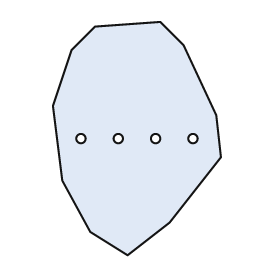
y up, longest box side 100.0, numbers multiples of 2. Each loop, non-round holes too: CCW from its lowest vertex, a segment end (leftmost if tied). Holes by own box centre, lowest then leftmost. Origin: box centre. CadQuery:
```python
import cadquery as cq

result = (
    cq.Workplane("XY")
    .moveTo(-4.0, -50.0)
    .lineTo(14.0, -36.0)
    .lineTo(36.0, -8.0)
    .lineTo(34.0, 10.0)
    .lineTo(20.0, 40.0)
    .lineTo(10.0, 50.0)
    .lineTo(-18.0, 48.0)
    .lineTo(-28.0, 38.0)
    .lineTo(-36.0, 14.0)
    .lineTo(-32.0, -18.0)
    .lineTo(-20.0, -40.0)
    .close()
    .moveTo(-24.0, 0.0)
    .circle(2.0)
    .moveTo(-8.0, 0.0)
    .circle(2.0)
    .moveTo(8.0, 0.0)
    .circle(2.0)
    .moveTo(24.0, 0.0)
    .circle(2.0)
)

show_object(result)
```